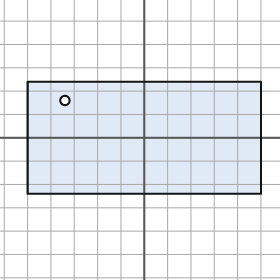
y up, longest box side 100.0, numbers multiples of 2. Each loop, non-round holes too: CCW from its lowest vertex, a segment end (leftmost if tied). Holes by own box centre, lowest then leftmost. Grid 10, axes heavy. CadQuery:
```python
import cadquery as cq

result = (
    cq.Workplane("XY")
    .moveTo(-50.0, -24.0)
    .lineTo(50.0, -24.0)
    .lineTo(50.0, 24.0)
    .lineTo(-50.0, 24.0)
    .close()
    .moveTo(-34.0, 16.0)
    .circle(2.0)
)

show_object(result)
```